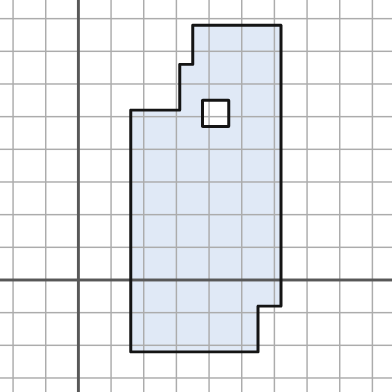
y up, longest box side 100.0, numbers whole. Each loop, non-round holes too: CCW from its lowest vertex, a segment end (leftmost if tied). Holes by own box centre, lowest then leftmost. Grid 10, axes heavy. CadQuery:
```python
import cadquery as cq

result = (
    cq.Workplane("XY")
    .moveTo(16.0, -22.0)
    .lineTo(55.0, -22.0)
    .lineTo(55.0, -8.0)
    .lineTo(62.0, -8.0)
    .lineTo(62.0, 78.0)
    .lineTo(35.0, 78.0)
    .lineTo(35.0, 66.0)
    .lineTo(31.0, 66.0)
    .lineTo(31.0, 52.0)
    .lineTo(16.0, 52.0)
    .close()
    .moveTo(38.0, 47.0)
    .lineTo(46.0, 47.0)
    .lineTo(46.0, 55.0)
    .lineTo(38.0, 55.0)
    .close()
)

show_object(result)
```